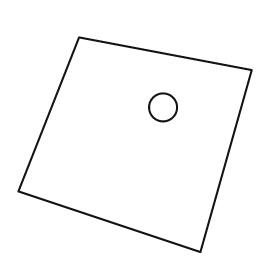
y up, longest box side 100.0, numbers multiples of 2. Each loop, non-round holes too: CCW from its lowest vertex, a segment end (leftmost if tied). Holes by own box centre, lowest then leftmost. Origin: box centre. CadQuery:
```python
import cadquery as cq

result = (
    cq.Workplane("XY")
    .moveTo(28.0, -46.0)
    .lineTo(50.0, 32.0)
    .lineTo(-24.0, 46.0)
    .lineTo(-50.0, -20.0)
    .close()
    .moveTo(12.0, 16.0)
    .circle(6.0)
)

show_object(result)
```